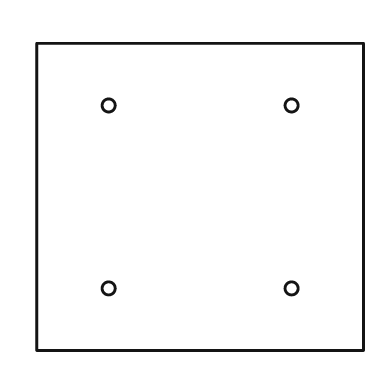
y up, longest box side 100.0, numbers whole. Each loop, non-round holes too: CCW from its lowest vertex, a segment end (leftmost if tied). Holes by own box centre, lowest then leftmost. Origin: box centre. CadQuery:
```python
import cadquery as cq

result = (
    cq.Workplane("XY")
    .moveTo(-50.0, -47.0)
    .lineTo(50.0, -47.0)
    .lineTo(50.0, 47.0)
    .lineTo(-50.0, 47.0)
    .close()
    .moveTo(-28.0, -28.0)
    .circle(2.0)
    .moveTo(28.0, -28.0)
    .circle(2.0)
    .moveTo(-28.0, 28.0)
    .circle(2.0)
    .moveTo(28.0, 28.0)
    .circle(2.0)
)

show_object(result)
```